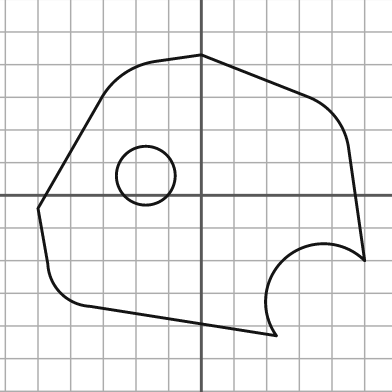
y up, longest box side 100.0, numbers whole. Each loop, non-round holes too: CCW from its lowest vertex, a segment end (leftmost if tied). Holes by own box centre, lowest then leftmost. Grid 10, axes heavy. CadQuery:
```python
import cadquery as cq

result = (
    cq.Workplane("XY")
    .moveTo(23.0, -43.0)
    .threePointArc((26.0, -19.0), (50.0, -20.0))
    .lineTo(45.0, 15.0)
    .threePointArc((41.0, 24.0), (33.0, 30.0))
    .lineTo(0.0, 43.0)
    .lineTo(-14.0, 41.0)
    .threePointArc((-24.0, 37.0), (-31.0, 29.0))
    .lineTo(-50.0, -4.0)
    .lineTo(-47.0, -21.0)
    .threePointArc((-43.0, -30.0), (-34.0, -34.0))
    .close()
    .moveTo(-17.0, 6.0)
    .circle(9.0)
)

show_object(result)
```